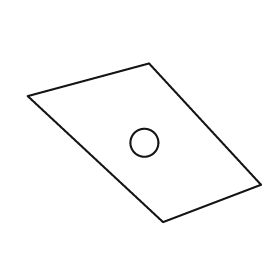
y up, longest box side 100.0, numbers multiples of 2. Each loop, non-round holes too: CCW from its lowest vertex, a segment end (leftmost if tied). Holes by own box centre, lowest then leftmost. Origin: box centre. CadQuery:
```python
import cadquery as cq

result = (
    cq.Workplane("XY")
    .moveTo(8.0, -34.0)
    .lineTo(50.0, -18.0)
    .lineTo(2.0, 34.0)
    .lineTo(-50.0, 20.0)
    .close()
    .moveTo(0.0, 0.0)
    .circle(6.0)
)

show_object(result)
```